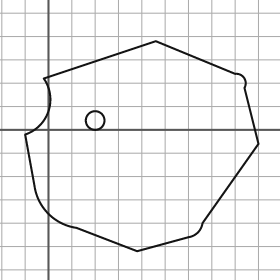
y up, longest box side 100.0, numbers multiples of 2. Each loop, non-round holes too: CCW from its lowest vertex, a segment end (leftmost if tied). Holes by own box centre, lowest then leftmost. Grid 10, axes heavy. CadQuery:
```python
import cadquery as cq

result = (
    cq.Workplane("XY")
    .moveTo(38.0, -52.0)
    .lineTo(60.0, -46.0)
    .threePointArc((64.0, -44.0), (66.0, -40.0))
    .lineTo(90.0, -6.0)
    .lineTo(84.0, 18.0)
    .threePointArc((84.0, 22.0), (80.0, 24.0))
    .lineTo(46.0, 38.0)
    .lineTo(-2.0, 22.0)
    .threePointArc((0.0, 8.0), (-10.0, -2.0))
    .lineTo(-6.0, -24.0)
    .threePointArc((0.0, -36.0), (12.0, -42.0))
    .close()
    .moveTo(20.0, 4.0)
    .circle(4.0)
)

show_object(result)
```